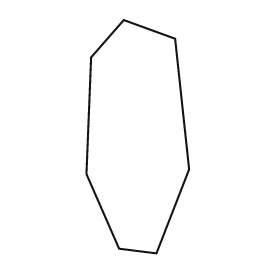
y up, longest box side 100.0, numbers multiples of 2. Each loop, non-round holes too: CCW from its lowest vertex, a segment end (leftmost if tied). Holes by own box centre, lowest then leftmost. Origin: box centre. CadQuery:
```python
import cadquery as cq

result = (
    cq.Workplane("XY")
    .moveTo(8.0, -50.0)
    .lineTo(22.0, -14.0)
    .lineTo(16.0, 42.0)
    .lineTo(-6.0, 50.0)
    .lineTo(-20.0, 34.0)
    .lineTo(-22.0, -16.0)
    .lineTo(-8.0, -48.0)
    .close()
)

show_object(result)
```